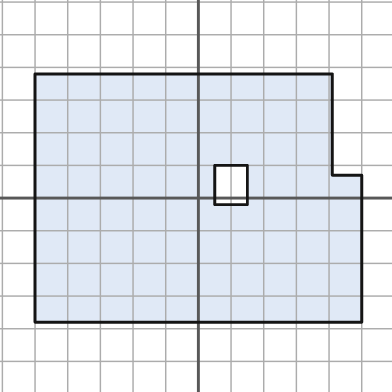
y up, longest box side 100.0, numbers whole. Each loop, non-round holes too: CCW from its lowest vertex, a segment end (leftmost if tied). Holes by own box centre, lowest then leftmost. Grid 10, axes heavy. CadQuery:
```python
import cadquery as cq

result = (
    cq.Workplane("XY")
    .moveTo(-50.0, -38.0)
    .lineTo(50.0, -38.0)
    .lineTo(50.0, 7.0)
    .lineTo(41.0, 7.0)
    .lineTo(41.0, 38.0)
    .lineTo(-50.0, 38.0)
    .close()
    .moveTo(5.0, -2.0)
    .lineTo(15.0, -2.0)
    .lineTo(15.0, 10.0)
    .lineTo(5.0, 10.0)
    .close()
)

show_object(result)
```